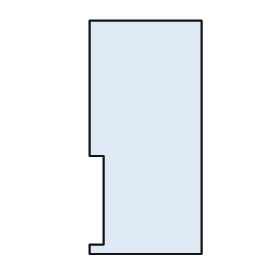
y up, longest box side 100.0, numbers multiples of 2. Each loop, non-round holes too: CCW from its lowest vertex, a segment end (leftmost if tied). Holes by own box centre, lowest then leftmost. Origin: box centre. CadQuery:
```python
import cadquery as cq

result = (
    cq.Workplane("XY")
    .moveTo(-24.0, -50.0)
    .lineTo(24.0, -50.0)
    .lineTo(24.0, 50.0)
    .lineTo(-24.0, 50.0)
    .lineTo(-24.0, -8.0)
    .lineTo(-18.0, -8.0)
    .lineTo(-18.0, -46.0)
    .lineTo(-24.0, -46.0)
    .close()
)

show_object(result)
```